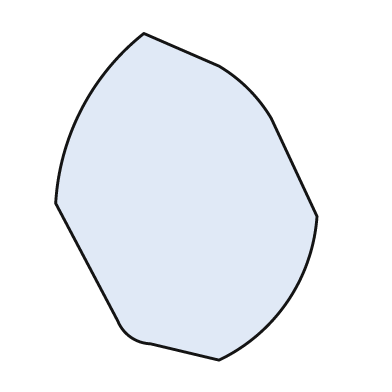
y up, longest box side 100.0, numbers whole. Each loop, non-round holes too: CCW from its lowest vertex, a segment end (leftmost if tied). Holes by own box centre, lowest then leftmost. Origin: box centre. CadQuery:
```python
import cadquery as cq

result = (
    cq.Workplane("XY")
    .moveTo(10.0, -50.0)
    .threePointArc((31.0, -32.0), (40.0, -6.0))
    .lineTo(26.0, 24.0)
    .threePointArc((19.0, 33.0), (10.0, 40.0))
    .lineTo(-13.0, 50.0)
    .threePointArc((-32.0, 27.0), (-40.0, -2.0))
    .lineTo(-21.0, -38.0)
    .threePointArc((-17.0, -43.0), (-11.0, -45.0))
    .close()
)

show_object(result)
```